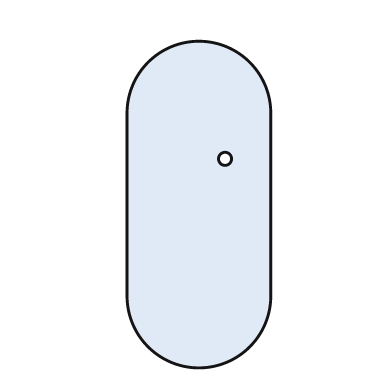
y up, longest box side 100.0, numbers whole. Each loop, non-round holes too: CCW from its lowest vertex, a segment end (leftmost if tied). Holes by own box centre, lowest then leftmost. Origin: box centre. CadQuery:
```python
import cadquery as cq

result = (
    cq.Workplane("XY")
    .moveTo(-22.0, -28.0)
    .threePointArc((0.0, -50.0), (22.0, -28.0))
    .lineTo(22.0, 28.0)
    .threePointArc((0.0, 50.0), (-22.0, 28.0))
    .close()
    .moveTo(8.0, 14.0)
    .circle(2.0)
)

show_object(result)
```